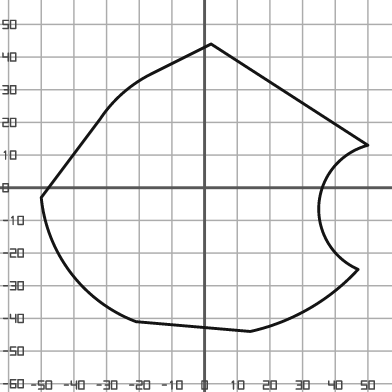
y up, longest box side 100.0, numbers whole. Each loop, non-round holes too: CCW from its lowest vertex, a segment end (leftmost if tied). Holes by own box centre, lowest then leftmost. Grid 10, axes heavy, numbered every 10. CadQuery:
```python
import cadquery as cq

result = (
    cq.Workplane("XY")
    .moveTo(14.0, -44.0)
    .threePointArc((32.0, -37.0), (47.0, -25.0))
    .threePointArc((35.0, -5.0), (50.0, 13.0))
    .lineTo(2.0, 44.0)
    .lineTo(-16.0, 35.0)
    .threePointArc((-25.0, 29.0), (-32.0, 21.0))
    .lineTo(-50.0, -3.0)
    .threePointArc((-41.0, -26.0), (-21.0, -41.0))
    .close()
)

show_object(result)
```